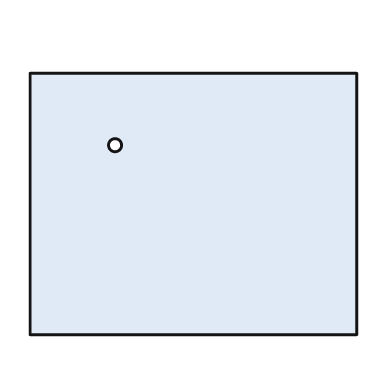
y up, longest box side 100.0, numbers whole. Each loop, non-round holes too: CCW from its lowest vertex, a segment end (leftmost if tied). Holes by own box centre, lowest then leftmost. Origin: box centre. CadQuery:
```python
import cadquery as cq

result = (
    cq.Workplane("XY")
    .moveTo(-50.0, -40.0)
    .lineTo(50.0, -40.0)
    .lineTo(50.0, 40.0)
    .lineTo(-50.0, 40.0)
    .close()
    .moveTo(-24.0, 18.0)
    .circle(2.0)
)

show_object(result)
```